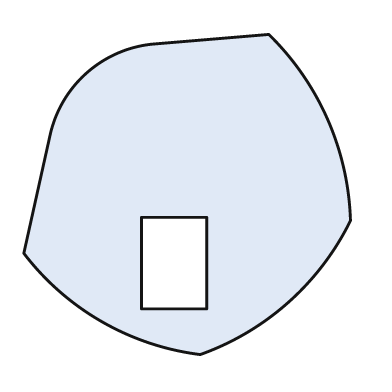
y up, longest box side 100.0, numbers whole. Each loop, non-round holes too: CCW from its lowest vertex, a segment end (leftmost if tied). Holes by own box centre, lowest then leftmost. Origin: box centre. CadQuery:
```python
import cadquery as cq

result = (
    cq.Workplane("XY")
    .moveTo(4.0, -49.0)
    .threePointArc((31.0, -33.0), (50.0, -8.0))
    .threePointArc((43.0, 23.0), (25.0, 49.0))
    .lineTo(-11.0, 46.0)
    .threePointArc((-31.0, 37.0), (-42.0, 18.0))
    .lineTo(-50.0, -18.0)
    .threePointArc((-26.0, -39.0), (4.0, -49.0))
    .close()
    .moveTo(-14.0, -35.0)
    .lineTo(6.0, -35.0)
    .lineTo(6.0, -7.0)
    .lineTo(-14.0, -7.0)
    .close()
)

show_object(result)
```